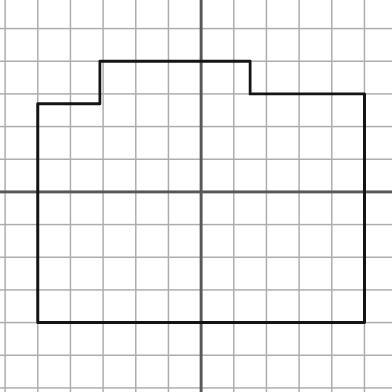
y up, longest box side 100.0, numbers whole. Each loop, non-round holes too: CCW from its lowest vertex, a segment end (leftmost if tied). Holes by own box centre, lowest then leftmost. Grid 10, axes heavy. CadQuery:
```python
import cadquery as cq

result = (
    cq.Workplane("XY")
    .moveTo(-50.0, -40.0)
    .lineTo(50.0, -40.0)
    .lineTo(50.0, 30.0)
    .lineTo(15.0, 30.0)
    .lineTo(15.0, 40.0)
    .lineTo(-31.0, 40.0)
    .lineTo(-31.0, 27.0)
    .lineTo(-50.0, 27.0)
    .close()
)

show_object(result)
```